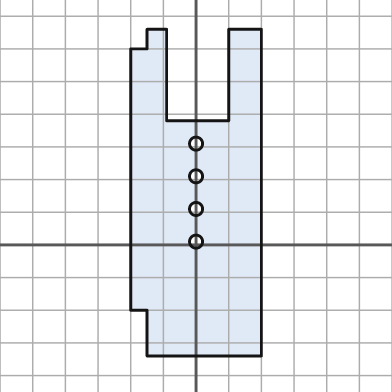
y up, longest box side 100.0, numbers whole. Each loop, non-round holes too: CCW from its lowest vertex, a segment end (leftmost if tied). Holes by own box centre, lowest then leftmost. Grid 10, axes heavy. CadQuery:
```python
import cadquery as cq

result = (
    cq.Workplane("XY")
    .moveTo(-15.0, -34.0)
    .lineTo(20.0, -34.0)
    .lineTo(20.0, 66.0)
    .lineTo(10.0, 66.0)
    .lineTo(10.0, 38.0)
    .lineTo(-9.0, 38.0)
    .lineTo(-9.0, 66.0)
    .lineTo(-15.0, 66.0)
    .lineTo(-15.0, 60.0)
    .lineTo(-20.0, 60.0)
    .lineTo(-20.0, -20.0)
    .lineTo(-15.0, -20.0)
    .close()
    .moveTo(0.0, 1.0)
    .circle(2.0)
    .moveTo(0.0, 11.0)
    .circle(2.0)
    .moveTo(0.0, 21.0)
    .circle(2.0)
    .moveTo(0.0, 31.0)
    .circle(2.0)
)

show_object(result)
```